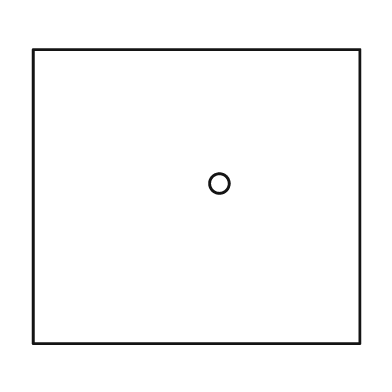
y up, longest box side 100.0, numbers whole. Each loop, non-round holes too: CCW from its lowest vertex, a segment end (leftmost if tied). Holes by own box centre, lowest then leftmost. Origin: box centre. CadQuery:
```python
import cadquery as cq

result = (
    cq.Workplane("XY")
    .moveTo(-50.0, -45.0)
    .lineTo(50.0, -45.0)
    .lineTo(50.0, 45.0)
    .lineTo(-50.0, 45.0)
    .close()
    .moveTo(7.0, 4.0)
    .circle(3.0)
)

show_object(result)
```